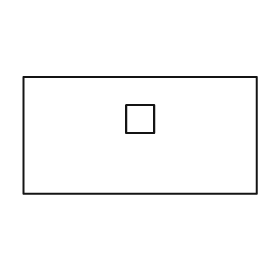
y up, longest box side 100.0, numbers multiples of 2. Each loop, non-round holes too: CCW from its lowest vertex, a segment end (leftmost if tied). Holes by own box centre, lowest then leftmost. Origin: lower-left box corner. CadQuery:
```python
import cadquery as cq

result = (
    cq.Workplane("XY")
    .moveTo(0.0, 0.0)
    .lineTo(100.0, 0.0)
    .lineTo(100.0, 50.0)
    .lineTo(0.0, 50.0)
    .close()
    .moveTo(44.0, 26.0)
    .lineTo(56.0, 26.0)
    .lineTo(56.0, 38.0)
    .lineTo(44.0, 38.0)
    .close()
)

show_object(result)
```